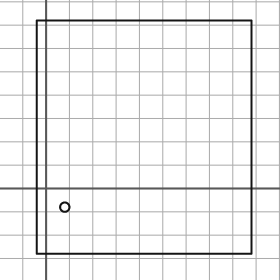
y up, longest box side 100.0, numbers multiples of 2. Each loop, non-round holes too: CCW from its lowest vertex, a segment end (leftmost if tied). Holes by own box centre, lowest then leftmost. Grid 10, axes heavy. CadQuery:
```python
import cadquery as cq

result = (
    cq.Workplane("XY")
    .moveTo(-4.0, -28.0)
    .lineTo(88.0, -28.0)
    .lineTo(88.0, 72.0)
    .lineTo(-4.0, 72.0)
    .close()
    .moveTo(8.0, -8.0)
    .circle(2.0)
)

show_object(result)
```